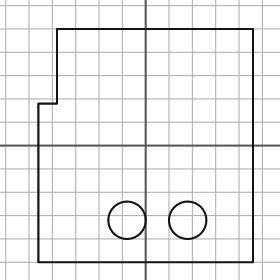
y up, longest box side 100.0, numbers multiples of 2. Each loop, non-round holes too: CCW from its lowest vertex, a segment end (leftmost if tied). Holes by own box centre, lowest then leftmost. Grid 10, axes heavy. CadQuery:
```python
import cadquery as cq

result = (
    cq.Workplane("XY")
    .moveTo(-46.0, -50.0)
    .lineTo(46.0, -50.0)
    .lineTo(46.0, 50.0)
    .lineTo(-38.0, 50.0)
    .lineTo(-38.0, 18.0)
    .lineTo(-46.0, 18.0)
    .close()
    .moveTo(-8.0, -32.0)
    .circle(8.0)
    .moveTo(18.0, -32.0)
    .circle(8.0)
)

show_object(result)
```